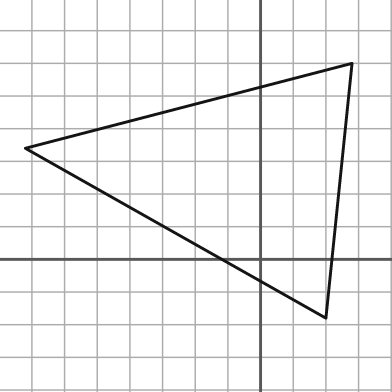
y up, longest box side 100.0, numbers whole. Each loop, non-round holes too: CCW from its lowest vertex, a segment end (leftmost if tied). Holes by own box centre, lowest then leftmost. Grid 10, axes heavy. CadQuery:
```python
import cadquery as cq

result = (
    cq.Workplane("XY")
    .moveTo(20.0, -18.0)
    .lineTo(28.0, 60.0)
    .lineTo(-72.0, 34.0)
    .close()
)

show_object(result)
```